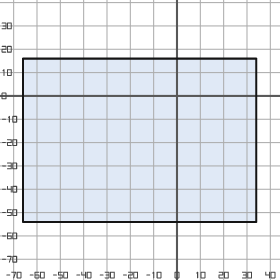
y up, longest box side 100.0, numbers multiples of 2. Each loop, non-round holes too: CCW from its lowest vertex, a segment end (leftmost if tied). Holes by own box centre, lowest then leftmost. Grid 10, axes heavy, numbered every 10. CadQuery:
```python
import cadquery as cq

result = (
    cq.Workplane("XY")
    .moveTo(-66.0, -54.0)
    .lineTo(34.0, -54.0)
    .lineTo(34.0, 16.0)
    .lineTo(-66.0, 16.0)
    .close()
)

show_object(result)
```